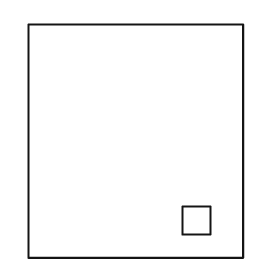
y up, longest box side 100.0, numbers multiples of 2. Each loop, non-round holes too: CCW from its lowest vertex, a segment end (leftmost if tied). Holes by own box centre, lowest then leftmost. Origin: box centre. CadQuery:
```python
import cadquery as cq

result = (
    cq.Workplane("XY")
    .moveTo(-46.0, -50.0)
    .lineTo(46.0, -50.0)
    .lineTo(46.0, 50.0)
    .lineTo(-46.0, 50.0)
    .close()
    .moveTo(20.0, -40.0)
    .lineTo(32.0, -40.0)
    .lineTo(32.0, -28.0)
    .lineTo(20.0, -28.0)
    .close()
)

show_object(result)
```